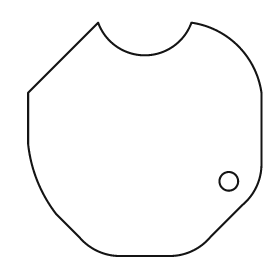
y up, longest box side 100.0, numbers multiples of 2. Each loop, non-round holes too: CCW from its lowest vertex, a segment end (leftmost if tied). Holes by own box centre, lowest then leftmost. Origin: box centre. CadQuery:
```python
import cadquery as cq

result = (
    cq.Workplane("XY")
    .moveTo(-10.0, -50.0)
    .lineTo(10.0, -50.0)
    .threePointArc((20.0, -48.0), (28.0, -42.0))
    .lineTo(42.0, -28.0)
    .threePointArc((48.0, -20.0), (50.0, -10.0))
    .lineTo(50.0, 20.0)
    .threePointArc((40.0, 40.0), (20.0, 50.0))
    .threePointArc((0.0, 36.0), (-20.0, 50.0))
    .lineTo(-50.0, 20.0)
    .lineTo(-50.0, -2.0)
    .threePointArc((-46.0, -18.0), (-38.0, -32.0))
    .lineTo(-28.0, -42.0)
    .threePointArc((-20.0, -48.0), (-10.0, -50.0))
    .close()
    .moveTo(36.0, -18.0)
    .circle(4.0)
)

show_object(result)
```